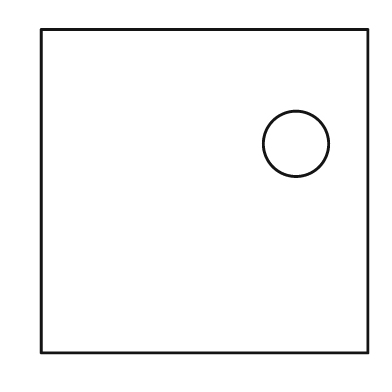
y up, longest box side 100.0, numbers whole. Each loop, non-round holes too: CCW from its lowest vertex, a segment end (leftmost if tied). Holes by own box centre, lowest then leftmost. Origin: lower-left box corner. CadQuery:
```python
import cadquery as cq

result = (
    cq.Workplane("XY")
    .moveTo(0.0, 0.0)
    .lineTo(100.0, 0.0)
    .lineTo(100.0, 99.0)
    .lineTo(0.0, 99.0)
    .close()
    .moveTo(78.0, 64.0)
    .circle(10.0)
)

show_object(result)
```